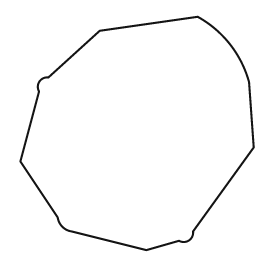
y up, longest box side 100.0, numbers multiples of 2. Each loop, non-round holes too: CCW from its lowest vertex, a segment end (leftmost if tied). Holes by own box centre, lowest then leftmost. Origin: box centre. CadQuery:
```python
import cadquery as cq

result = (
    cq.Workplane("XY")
    .moveTo(4.0, -50.0)
    .lineTo(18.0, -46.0)
    .threePointArc((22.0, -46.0), (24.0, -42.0))
    .lineTo(50.0, -6.0)
    .lineTo(48.0, 22.0)
    .threePointArc((40.0, 38.0), (26.0, 50.0))
    .lineTo(-16.0, 44.0)
    .lineTo(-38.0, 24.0)
    .threePointArc((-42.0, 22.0), (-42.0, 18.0))
    .lineTo(-50.0, -12.0)
    .lineTo(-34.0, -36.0)
    .threePointArc((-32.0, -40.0), (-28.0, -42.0))
    .close()
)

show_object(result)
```